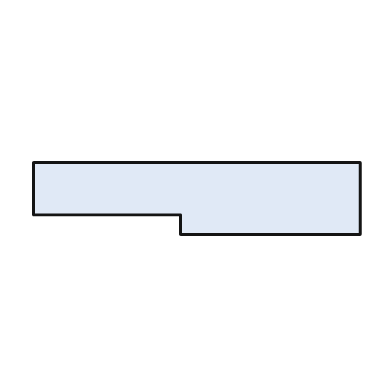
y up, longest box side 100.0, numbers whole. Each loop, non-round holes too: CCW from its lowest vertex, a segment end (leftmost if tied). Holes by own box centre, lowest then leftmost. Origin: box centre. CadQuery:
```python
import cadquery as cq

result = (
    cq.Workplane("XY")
    .moveTo(-5.0, -11.0)
    .lineTo(50.0, -11.0)
    .lineTo(50.0, 11.0)
    .lineTo(-50.0, 11.0)
    .lineTo(-50.0, -5.0)
    .lineTo(-5.0, -5.0)
    .close()
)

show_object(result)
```